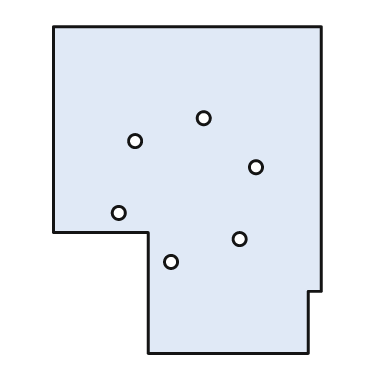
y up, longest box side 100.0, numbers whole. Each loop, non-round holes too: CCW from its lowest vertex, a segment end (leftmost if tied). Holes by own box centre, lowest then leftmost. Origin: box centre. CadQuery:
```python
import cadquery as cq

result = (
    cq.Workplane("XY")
    .moveTo(-12.0, -50.0)
    .lineTo(37.0, -50.0)
    .lineTo(37.0, -31.0)
    .lineTo(41.0, -31.0)
    .lineTo(41.0, 50.0)
    .lineTo(-41.0, 50.0)
    .lineTo(-41.0, -13.0)
    .lineTo(-12.0, -13.0)
    .close()
    .moveTo(-5.0, -22.0)
    .circle(2.0)
    .moveTo(16.0, -15.0)
    .circle(2.0)
    .moveTo(-21.0, -7.0)
    .circle(2.0)
    .moveTo(21.0, 7.0)
    .circle(2.0)
    .moveTo(-16.0, 15.0)
    .circle(2.0)
    .moveTo(5.0, 22.0)
    .circle(2.0)
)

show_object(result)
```